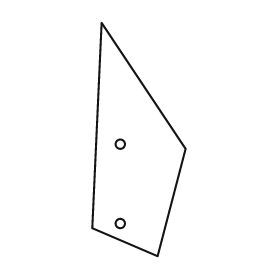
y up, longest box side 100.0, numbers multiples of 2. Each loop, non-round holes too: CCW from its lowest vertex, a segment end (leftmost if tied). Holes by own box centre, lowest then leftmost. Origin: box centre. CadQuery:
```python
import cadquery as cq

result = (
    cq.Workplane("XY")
    .moveTo(8.0, -50.0)
    .lineTo(20.0, -4.0)
    .lineTo(-16.0, 50.0)
    .lineTo(-20.0, -38.0)
    .close()
    .moveTo(-8.0, -36.0)
    .circle(2.0)
    .moveTo(-8.0, -2.0)
    .circle(2.0)
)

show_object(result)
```